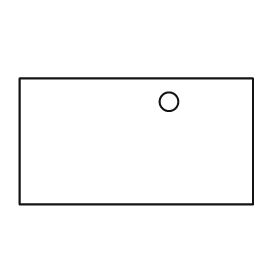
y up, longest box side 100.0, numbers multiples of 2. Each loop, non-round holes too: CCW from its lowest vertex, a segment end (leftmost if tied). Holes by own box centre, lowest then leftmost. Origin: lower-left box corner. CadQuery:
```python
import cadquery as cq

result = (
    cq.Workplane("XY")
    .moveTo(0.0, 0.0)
    .lineTo(100.0, 0.0)
    .lineTo(100.0, 54.0)
    .lineTo(0.0, 54.0)
    .close()
    .moveTo(64.0, 44.0)
    .circle(4.0)
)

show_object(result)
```